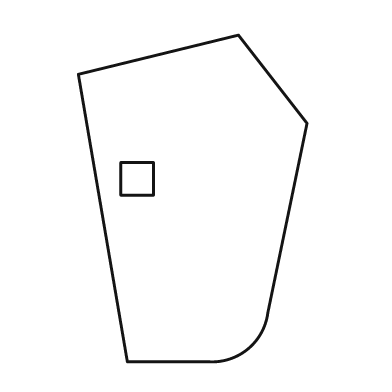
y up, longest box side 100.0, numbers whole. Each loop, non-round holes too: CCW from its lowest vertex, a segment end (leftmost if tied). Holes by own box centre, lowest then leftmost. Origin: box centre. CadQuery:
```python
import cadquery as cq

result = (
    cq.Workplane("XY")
    .moveTo(-20.0, -50.0)
    .lineTo(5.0, -50.0)
    .threePointArc((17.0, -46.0), (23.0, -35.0))
    .lineTo(35.0, 23.0)
    .lineTo(14.0, 50.0)
    .lineTo(-35.0, 38.0)
    .close()
    .moveTo(-22.0, 1.0)
    .lineTo(-12.0, 1.0)
    .lineTo(-12.0, 11.0)
    .lineTo(-22.0, 11.0)
    .close()
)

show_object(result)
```